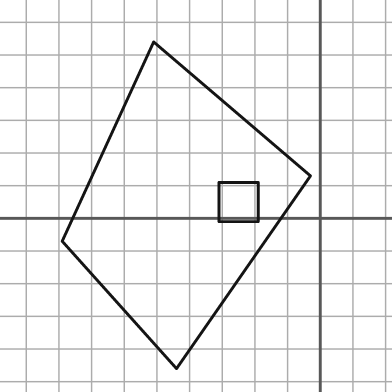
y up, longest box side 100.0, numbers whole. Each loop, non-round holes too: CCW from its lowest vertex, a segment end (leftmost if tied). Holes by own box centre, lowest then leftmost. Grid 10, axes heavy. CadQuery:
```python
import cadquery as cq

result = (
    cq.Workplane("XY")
    .moveTo(-44.0, -46.0)
    .lineTo(-3.0, 13.0)
    .lineTo(-51.0, 54.0)
    .lineTo(-79.0, -7.0)
    .close()
    .moveTo(-31.0, -1.0)
    .lineTo(-19.0, -1.0)
    .lineTo(-19.0, 11.0)
    .lineTo(-31.0, 11.0)
    .close()
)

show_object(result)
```